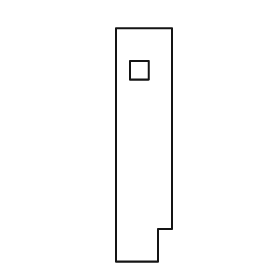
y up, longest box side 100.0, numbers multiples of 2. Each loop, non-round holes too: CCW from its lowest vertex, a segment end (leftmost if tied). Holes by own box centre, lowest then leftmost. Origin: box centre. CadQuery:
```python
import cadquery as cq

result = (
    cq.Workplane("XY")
    .moveTo(-12.0, -50.0)
    .lineTo(6.0, -50.0)
    .lineTo(6.0, -36.0)
    .lineTo(12.0, -36.0)
    .lineTo(12.0, 50.0)
    .lineTo(-12.0, 50.0)
    .close()
    .moveTo(-6.0, 28.0)
    .lineTo(2.0, 28.0)
    .lineTo(2.0, 36.0)
    .lineTo(-6.0, 36.0)
    .close()
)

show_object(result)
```